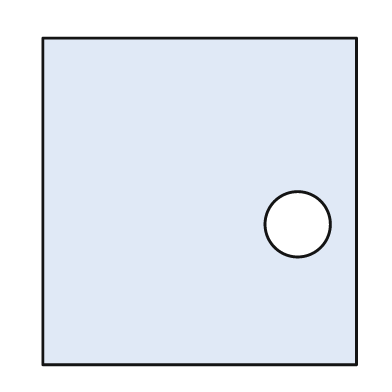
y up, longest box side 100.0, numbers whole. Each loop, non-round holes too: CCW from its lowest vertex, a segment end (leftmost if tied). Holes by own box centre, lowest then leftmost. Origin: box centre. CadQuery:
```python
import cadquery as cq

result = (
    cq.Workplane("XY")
    .moveTo(-48.0, -50.0)
    .lineTo(48.0, -50.0)
    .lineTo(48.0, 50.0)
    .lineTo(-48.0, 50.0)
    .close()
    .moveTo(30.0, -7.0)
    .circle(10.0)
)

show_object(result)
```